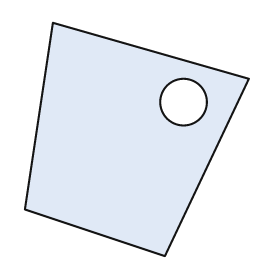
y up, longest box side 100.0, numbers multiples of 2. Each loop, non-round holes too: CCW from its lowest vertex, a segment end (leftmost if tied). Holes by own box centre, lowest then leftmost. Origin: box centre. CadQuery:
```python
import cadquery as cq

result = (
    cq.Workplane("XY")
    .moveTo(12.0, -50.0)
    .lineTo(48.0, 26.0)
    .lineTo(-36.0, 50.0)
    .lineTo(-48.0, -30.0)
    .close()
    .moveTo(20.0, 16.0)
    .circle(10.0)
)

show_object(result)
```